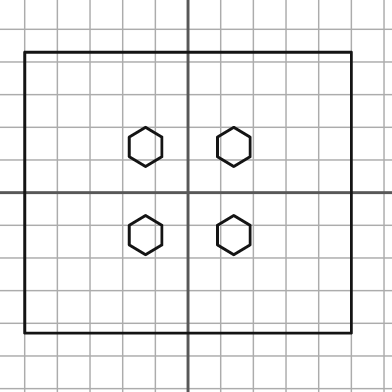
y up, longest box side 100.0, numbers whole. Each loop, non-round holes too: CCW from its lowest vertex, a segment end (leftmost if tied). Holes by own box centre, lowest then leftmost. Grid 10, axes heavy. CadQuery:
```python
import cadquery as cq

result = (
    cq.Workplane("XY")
    .moveTo(-50.0, -43.0)
    .lineTo(50.0, -43.0)
    .lineTo(50.0, 43.0)
    .lineTo(-50.0, 43.0)
    .close()
    .moveTo(-13.0, -19.0)
    .lineTo(-8.0, -16.0)
    .lineTo(-8.0, -10.0)
    .lineTo(-13.0, -7.0)
    .lineTo(-18.0, -10.0)
    .lineTo(-18.0, -16.0)
    .close()
    .moveTo(14.0, -19.0)
    .lineTo(19.0, -16.0)
    .lineTo(19.0, -10.0)
    .lineTo(14.0, -7.0)
    .lineTo(9.0, -10.0)
    .lineTo(9.0, -16.0)
    .close()
    .moveTo(-13.0, 8.0)
    .lineTo(-8.0, 11.0)
    .lineTo(-8.0, 17.0)
    .lineTo(-13.0, 20.0)
    .lineTo(-18.0, 17.0)
    .lineTo(-18.0, 11.0)
    .close()
    .moveTo(14.0, 8.0)
    .lineTo(19.0, 11.0)
    .lineTo(19.0, 17.0)
    .lineTo(14.0, 20.0)
    .lineTo(9.0, 17.0)
    .lineTo(9.0, 11.0)
    .close()
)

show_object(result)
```